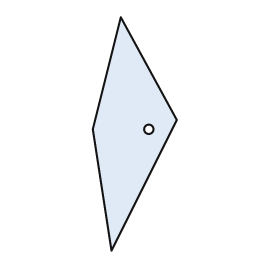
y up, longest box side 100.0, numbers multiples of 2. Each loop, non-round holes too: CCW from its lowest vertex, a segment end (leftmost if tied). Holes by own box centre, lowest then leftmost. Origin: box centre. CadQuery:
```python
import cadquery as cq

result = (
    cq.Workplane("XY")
    .moveTo(-10.0, -50.0)
    .lineTo(18.0, 6.0)
    .lineTo(-6.0, 50.0)
    .lineTo(-18.0, 2.0)
    .close()
    .moveTo(6.0, 2.0)
    .circle(2.0)
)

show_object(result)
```